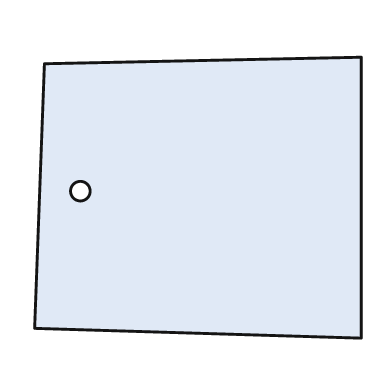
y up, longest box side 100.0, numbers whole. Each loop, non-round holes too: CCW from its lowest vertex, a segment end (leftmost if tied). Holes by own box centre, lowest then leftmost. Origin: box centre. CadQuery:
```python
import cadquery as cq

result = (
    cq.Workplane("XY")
    .moveTo(50.0, -43.0)
    .lineTo(50.0, 43.0)
    .lineTo(-47.0, 41.0)
    .lineTo(-50.0, -40.0)
    .close()
    .moveTo(-36.0, 2.0)
    .circle(3.0)
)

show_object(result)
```